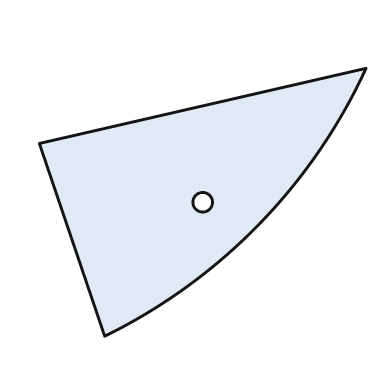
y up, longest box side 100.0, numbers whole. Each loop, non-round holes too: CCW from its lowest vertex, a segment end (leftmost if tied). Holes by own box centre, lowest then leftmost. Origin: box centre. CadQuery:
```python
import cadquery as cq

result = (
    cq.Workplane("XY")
    .moveTo(-30.0, -41.0)
    .threePointArc((17.0, -7.0), (50.0, 41.0))
    .lineTo(-50.0, 18.0)
    .close()
    .moveTo(0.0, 0.0)
    .circle(3.0)
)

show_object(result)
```